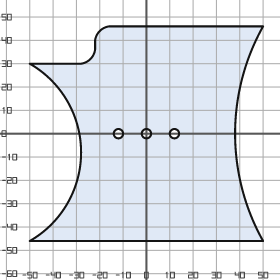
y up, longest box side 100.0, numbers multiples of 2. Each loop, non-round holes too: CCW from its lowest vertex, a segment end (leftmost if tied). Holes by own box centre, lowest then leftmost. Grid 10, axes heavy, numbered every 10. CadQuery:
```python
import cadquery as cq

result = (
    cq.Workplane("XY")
    .moveTo(-50.0, -46.0)
    .lineTo(50.0, -46.0)
    .threePointArc((38.0, 0.0), (50.0, 46.0))
    .lineTo(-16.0, 46.0)
    .threePointArc((-20.0, 44.0), (-22.0, 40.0))
    .lineTo(-22.0, 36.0)
    .threePointArc((-24.0, 32.0), (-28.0, 30.0))
    .lineTo(-50.0, 30.0)
    .threePointArc((-28.0, -8.0), (-50.0, -46.0))
    .close()
    .moveTo(-12.0, 0.0)
    .circle(2.0)
    .moveTo(0.0, 0.0)
    .circle(2.0)
    .moveTo(12.0, 0.0)
    .circle(2.0)
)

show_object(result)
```